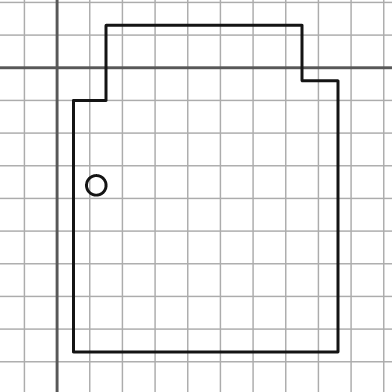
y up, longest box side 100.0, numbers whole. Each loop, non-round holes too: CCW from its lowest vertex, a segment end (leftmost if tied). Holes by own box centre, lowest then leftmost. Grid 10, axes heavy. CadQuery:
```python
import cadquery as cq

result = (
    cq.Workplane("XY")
    .moveTo(5.0, -87.0)
    .lineTo(86.0, -87.0)
    .lineTo(86.0, -4.0)
    .lineTo(75.0, -4.0)
    .lineTo(75.0, 13.0)
    .lineTo(15.0, 13.0)
    .lineTo(15.0, -10.0)
    .lineTo(5.0, -10.0)
    .close()
    .moveTo(12.0, -36.0)
    .circle(3.0)
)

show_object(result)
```